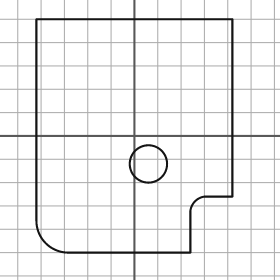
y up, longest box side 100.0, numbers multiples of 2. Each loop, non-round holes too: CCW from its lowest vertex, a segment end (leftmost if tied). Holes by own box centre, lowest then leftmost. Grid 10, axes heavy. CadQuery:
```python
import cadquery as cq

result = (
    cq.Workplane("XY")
    .moveTo(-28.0, -50.0)
    .lineTo(24.0, -50.0)
    .lineTo(24.0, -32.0)
    .threePointArc((26.0, -28.0), (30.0, -26.0))
    .lineTo(42.0, -26.0)
    .lineTo(42.0, 50.0)
    .lineTo(-42.0, 50.0)
    .lineTo(-42.0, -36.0)
    .threePointArc((-38.0, -46.0), (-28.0, -50.0))
    .close()
    .moveTo(6.0, -12.0)
    .circle(8.0)
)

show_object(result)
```